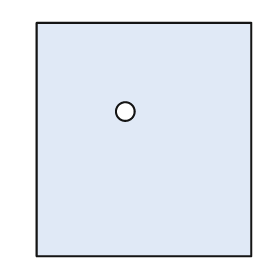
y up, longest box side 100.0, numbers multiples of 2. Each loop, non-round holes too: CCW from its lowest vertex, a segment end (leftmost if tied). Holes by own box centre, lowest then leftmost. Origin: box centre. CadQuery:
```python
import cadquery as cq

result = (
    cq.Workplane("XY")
    .moveTo(-46.0, -50.0)
    .lineTo(46.0, -50.0)
    .lineTo(46.0, 50.0)
    .lineTo(-46.0, 50.0)
    .close()
    .moveTo(-8.0, 12.0)
    .circle(4.0)
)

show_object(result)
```